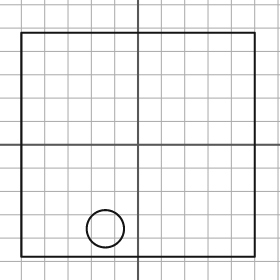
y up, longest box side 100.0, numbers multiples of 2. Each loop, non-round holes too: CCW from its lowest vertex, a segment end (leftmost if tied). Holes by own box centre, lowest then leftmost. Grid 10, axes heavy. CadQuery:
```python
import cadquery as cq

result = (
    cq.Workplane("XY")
    .moveTo(-50.0, -48.0)
    .lineTo(50.0, -48.0)
    .lineTo(50.0, 48.0)
    .lineTo(-50.0, 48.0)
    .close()
    .moveTo(-14.0, -36.0)
    .circle(8.0)
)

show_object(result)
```